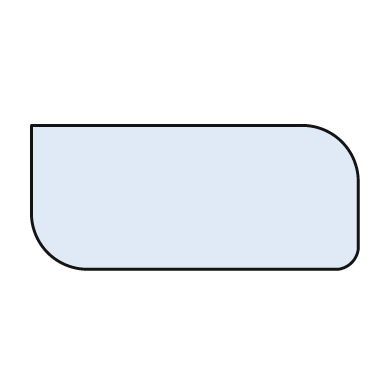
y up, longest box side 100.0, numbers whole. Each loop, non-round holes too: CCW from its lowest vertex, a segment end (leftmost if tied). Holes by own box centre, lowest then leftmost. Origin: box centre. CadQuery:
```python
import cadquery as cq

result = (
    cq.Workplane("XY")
    .moveTo(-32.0, -22.0)
    .lineTo(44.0, -22.0)
    .threePointArc((48.0, -20.0), (50.0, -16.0))
    .lineTo(50.0, 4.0)
    .threePointArc((45.0, 17.0), (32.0, 22.0))
    .lineTo(-50.0, 22.0)
    .lineTo(-50.0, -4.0)
    .threePointArc((-45.0, -17.0), (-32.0, -22.0))
    .close()
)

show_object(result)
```